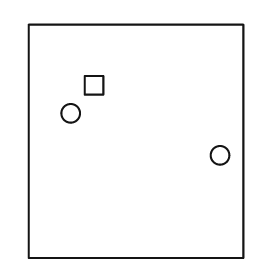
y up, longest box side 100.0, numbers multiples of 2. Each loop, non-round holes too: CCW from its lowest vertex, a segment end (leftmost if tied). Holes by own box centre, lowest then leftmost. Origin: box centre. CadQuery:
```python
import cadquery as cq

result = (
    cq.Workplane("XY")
    .moveTo(-46.0, -50.0)
    .lineTo(46.0, -50.0)
    .lineTo(46.0, 50.0)
    .lineTo(-46.0, 50.0)
    .close()
    .moveTo(36.0, -6.0)
    .circle(4.0)
    .moveTo(-28.0, 12.0)
    .circle(4.0)
    .moveTo(-22.0, 20.0)
    .lineTo(-14.0, 20.0)
    .lineTo(-14.0, 28.0)
    .lineTo(-22.0, 28.0)
    .close()
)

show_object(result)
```